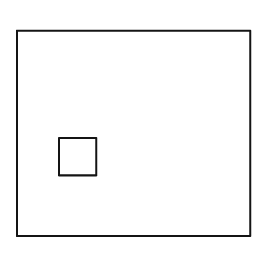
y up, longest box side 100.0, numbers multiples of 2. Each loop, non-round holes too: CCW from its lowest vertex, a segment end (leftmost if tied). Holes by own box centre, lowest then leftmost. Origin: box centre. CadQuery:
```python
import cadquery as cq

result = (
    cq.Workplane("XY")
    .moveTo(-50.0, -44.0)
    .lineTo(50.0, -44.0)
    .lineTo(50.0, 44.0)
    .lineTo(-50.0, 44.0)
    .close()
    .moveTo(-32.0, -18.0)
    .lineTo(-16.0, -18.0)
    .lineTo(-16.0, -2.0)
    .lineTo(-32.0, -2.0)
    .close()
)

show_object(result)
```